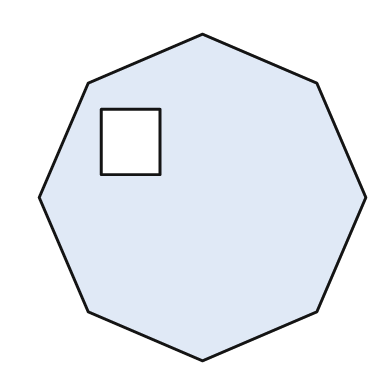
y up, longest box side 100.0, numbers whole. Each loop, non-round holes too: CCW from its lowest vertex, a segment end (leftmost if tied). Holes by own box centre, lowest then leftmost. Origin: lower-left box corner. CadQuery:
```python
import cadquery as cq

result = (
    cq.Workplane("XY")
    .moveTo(50.0, 0.0)
    .lineTo(85.0, 15.0)
    .lineTo(100.0, 50.0)
    .lineTo(85.0, 85.0)
    .lineTo(50.0, 100.0)
    .lineTo(15.0, 85.0)
    .lineTo(0.0, 50.0)
    .lineTo(15.0, 15.0)
    .close()
    .moveTo(19.0, 57.0)
    .lineTo(37.0, 57.0)
    .lineTo(37.0, 77.0)
    .lineTo(19.0, 77.0)
    .close()
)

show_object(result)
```